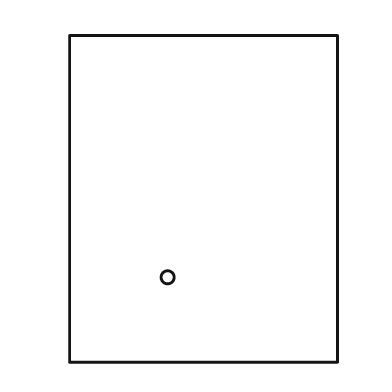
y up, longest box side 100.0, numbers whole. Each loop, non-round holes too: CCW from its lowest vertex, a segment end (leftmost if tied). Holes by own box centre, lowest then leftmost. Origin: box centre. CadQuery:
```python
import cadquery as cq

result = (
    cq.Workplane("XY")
    .moveTo(-41.0, -50.0)
    .lineTo(41.0, -50.0)
    .lineTo(41.0, 50.0)
    .lineTo(-41.0, 50.0)
    .close()
    .moveTo(-11.0, -24.0)
    .circle(2.0)
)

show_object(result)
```